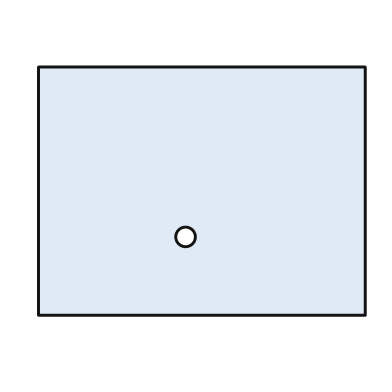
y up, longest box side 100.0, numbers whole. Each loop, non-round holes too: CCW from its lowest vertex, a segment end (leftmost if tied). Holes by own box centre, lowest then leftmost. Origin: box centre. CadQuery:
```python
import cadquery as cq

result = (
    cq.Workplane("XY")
    .moveTo(-50.0, -38.0)
    .lineTo(50.0, -38.0)
    .lineTo(50.0, 38.0)
    .lineTo(-50.0, 38.0)
    .close()
    .moveTo(-5.0, -14.0)
    .circle(3.0)
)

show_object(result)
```